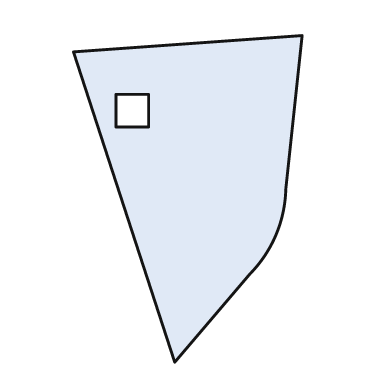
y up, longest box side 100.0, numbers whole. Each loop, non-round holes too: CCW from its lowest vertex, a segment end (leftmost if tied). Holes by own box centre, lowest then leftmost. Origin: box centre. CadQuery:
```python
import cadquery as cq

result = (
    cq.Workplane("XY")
    .moveTo(-4.0, -50.0)
    .lineTo(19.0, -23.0)
    .threePointArc((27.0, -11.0), (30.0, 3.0))
    .lineTo(35.0, 50.0)
    .lineTo(-35.0, 45.0)
    .close()
    .moveTo(-22.0, 22.0)
    .lineTo(-12.0, 22.0)
    .lineTo(-12.0, 32.0)
    .lineTo(-22.0, 32.0)
    .close()
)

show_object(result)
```